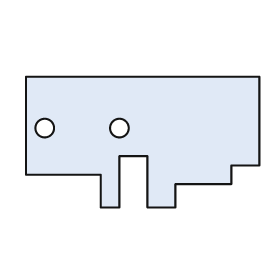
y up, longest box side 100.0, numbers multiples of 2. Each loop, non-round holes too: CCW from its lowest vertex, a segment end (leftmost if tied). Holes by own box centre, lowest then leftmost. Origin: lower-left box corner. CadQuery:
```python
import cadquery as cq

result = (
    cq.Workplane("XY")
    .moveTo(32.0, 0.0)
    .lineTo(40.0, 0.0)
    .lineTo(40.0, 22.0)
    .lineTo(52.0, 22.0)
    .lineTo(52.0, 0.0)
    .lineTo(64.0, 0.0)
    .lineTo(64.0, 10.0)
    .lineTo(88.0, 10.0)
    .lineTo(88.0, 18.0)
    .lineTo(100.0, 18.0)
    .lineTo(100.0, 56.0)
    .lineTo(0.0, 56.0)
    .lineTo(0.0, 14.0)
    .lineTo(32.0, 14.0)
    .close()
    .moveTo(8.0, 34.0)
    .circle(4.0)
    .moveTo(40.0, 34.0)
    .circle(4.0)
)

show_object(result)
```